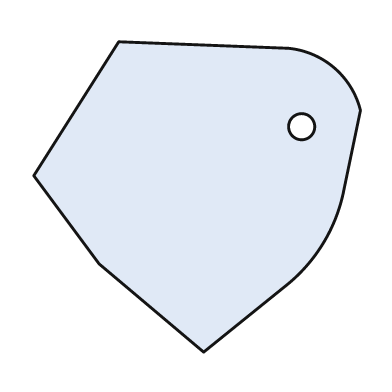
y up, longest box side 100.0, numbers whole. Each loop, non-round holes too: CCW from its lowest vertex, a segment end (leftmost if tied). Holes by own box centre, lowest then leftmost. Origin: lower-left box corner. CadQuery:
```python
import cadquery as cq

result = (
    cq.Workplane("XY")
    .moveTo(52.0, 0.0)
    .lineTo(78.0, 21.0)
    .threePointArc((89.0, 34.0), (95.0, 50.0))
    .lineTo(100.0, 74.0)
    .threePointArc((92.0, 87.0), (78.0, 93.0))
    .lineTo(26.0, 95.0)
    .lineTo(0.0, 54.0)
    .lineTo(20.0, 27.0)
    .close()
    .moveTo(82.0, 69.0)
    .circle(4.0)
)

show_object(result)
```